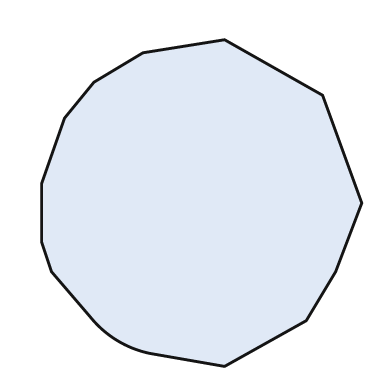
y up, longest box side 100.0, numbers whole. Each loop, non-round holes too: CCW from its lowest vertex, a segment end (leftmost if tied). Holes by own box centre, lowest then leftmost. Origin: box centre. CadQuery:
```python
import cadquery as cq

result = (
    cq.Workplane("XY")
    .moveTo(7.0, -50.0)
    .lineTo(32.0, -36.0)
    .lineTo(41.0, -21.0)
    .lineTo(49.0, 0.0)
    .lineTo(37.0, 33.0)
    .lineTo(7.0, 50.0)
    .lineTo(-18.0, 46.0)
    .lineTo(-33.0, 37.0)
    .lineTo(-42.0, 26.0)
    .lineTo(-49.0, 6.0)
    .lineTo(-49.0, -12.0)
    .lineTo(-46.0, -21.0)
    .lineTo(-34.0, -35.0)
    .threePointArc((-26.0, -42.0), (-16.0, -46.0))
    .close()
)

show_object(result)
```